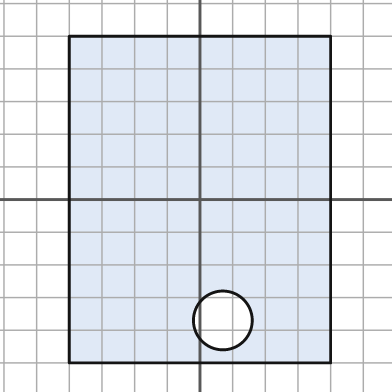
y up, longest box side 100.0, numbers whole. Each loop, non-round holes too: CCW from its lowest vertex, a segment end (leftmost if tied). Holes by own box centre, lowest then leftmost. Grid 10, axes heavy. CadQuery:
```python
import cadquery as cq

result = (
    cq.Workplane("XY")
    .moveTo(-40.0, -50.0)
    .lineTo(40.0, -50.0)
    .lineTo(40.0, 50.0)
    .lineTo(-40.0, 50.0)
    .close()
    .moveTo(7.0, -37.0)
    .circle(9.0)
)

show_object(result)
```